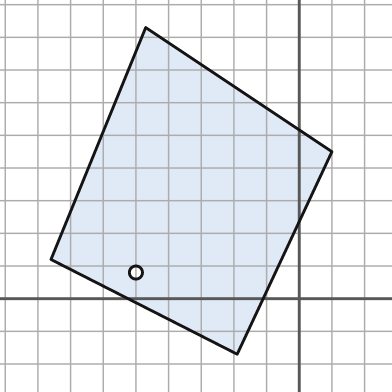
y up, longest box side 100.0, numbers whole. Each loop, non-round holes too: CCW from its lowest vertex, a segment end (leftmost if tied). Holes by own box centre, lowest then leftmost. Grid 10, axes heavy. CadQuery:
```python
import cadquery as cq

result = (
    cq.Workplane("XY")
    .moveTo(-19.0, -17.0)
    .lineTo(10.0, 45.0)
    .lineTo(-47.0, 83.0)
    .lineTo(-76.0, 12.0)
    .close()
    .moveTo(-50.0, 8.0)
    .circle(2.0)
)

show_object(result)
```